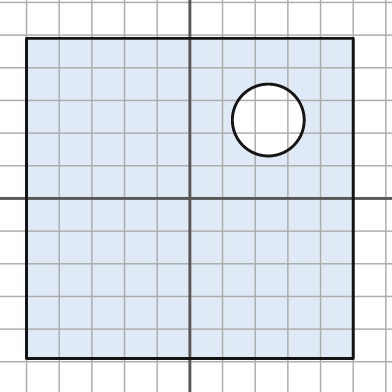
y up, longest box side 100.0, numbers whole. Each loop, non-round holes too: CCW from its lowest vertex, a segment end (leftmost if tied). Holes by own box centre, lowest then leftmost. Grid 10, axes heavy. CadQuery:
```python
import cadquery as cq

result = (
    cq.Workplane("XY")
    .moveTo(-50.0, -49.0)
    .lineTo(50.0, -49.0)
    .lineTo(50.0, 49.0)
    .lineTo(-50.0, 49.0)
    .close()
    .moveTo(24.0, 24.0)
    .circle(11.0)
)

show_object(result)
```